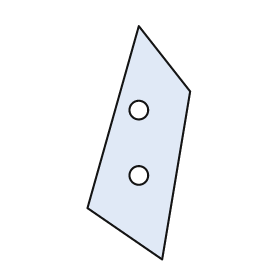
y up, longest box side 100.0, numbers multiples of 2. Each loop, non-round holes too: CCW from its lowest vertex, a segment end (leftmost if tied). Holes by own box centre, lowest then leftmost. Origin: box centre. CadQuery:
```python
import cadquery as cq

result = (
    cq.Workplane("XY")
    .moveTo(10.0, -50.0)
    .lineTo(22.0, 22.0)
    .lineTo(0.0, 50.0)
    .lineTo(-22.0, -28.0)
    .close()
    .moveTo(0.0, -14.0)
    .circle(4.0)
    .moveTo(0.0, 14.0)
    .circle(4.0)
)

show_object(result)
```